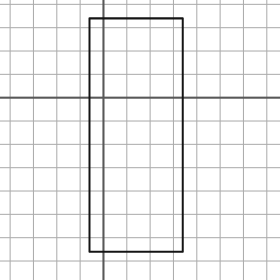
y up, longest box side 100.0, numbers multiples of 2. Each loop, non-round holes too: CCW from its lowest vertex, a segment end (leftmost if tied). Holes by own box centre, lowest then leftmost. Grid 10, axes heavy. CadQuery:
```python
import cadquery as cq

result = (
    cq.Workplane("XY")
    .moveTo(-6.0, -66.0)
    .lineTo(34.0, -66.0)
    .lineTo(34.0, 34.0)
    .lineTo(-6.0, 34.0)
    .close()
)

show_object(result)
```